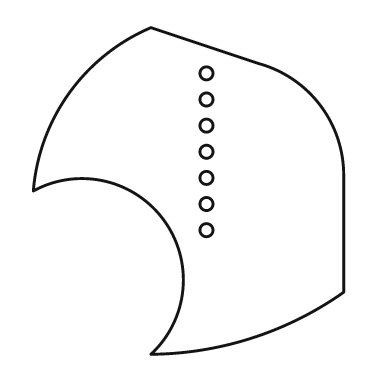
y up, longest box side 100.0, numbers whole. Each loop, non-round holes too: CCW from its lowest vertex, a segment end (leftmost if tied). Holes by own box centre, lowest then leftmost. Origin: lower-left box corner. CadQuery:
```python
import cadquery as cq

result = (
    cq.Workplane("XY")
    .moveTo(36.0, 0.0)
    .threePointArc((67.0, 5.0), (95.0, 19.0))
    .lineTo(95.0, 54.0)
    .threePointArc((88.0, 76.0), (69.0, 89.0))
    .lineTo(36.0, 100.0)
    .threePointArc((11.0, 80.0), (0.0, 50.0))
    .threePointArc((40.0, 41.0), (36.0, 0.0))
    .close()
    .moveTo(53.0, 38.0)
    .circle(2.0)
    .moveTo(53.0, 46.0)
    .circle(2.0)
    .moveTo(53.0, 54.0)
    .circle(2.0)
    .moveTo(53.0, 62.0)
    .circle(2.0)
    .moveTo(53.0, 70.0)
    .circle(2.0)
    .moveTo(53.0, 78.0)
    .circle(2.0)
    .moveTo(53.0, 86.0)
    .circle(2.0)
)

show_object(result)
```